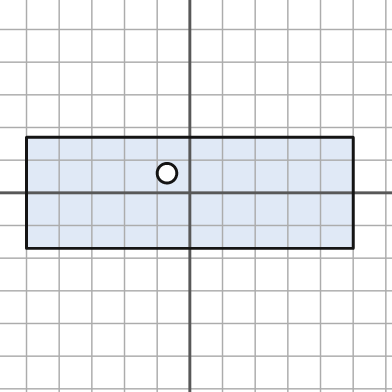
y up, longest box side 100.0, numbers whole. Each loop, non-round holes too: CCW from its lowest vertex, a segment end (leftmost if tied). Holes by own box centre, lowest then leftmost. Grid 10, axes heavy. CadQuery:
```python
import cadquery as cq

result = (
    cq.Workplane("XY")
    .moveTo(-50.0, -17.0)
    .lineTo(50.0, -17.0)
    .lineTo(50.0, 17.0)
    .lineTo(-50.0, 17.0)
    .close()
    .moveTo(-7.0, 6.0)
    .circle(3.0)
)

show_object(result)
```